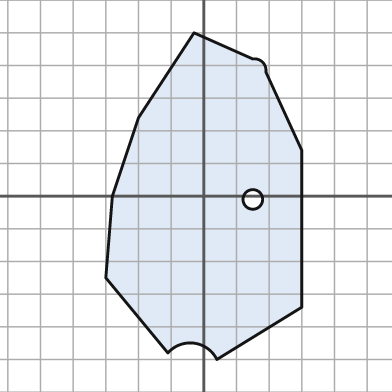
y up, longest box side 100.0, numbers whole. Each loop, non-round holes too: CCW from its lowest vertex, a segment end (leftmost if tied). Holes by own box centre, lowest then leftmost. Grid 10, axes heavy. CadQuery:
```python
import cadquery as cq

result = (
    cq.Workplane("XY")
    .moveTo(4.0, -50.0)
    .lineTo(30.0, -34.0)
    .lineTo(30.0, 14.0)
    .lineTo(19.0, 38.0)
    .threePointArc((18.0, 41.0), (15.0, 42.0))
    .lineTo(-3.0, 50.0)
    .lineTo(-20.0, 24.0)
    .lineTo(-28.0, 0.0)
    .lineTo(-30.0, -25.0)
    .lineTo(-11.0, -48.0)
    .threePointArc((-3.0, -45.0), (4.0, -50.0))
    .close()
    .moveTo(15.0, -1.0)
    .circle(3.0)
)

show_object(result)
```